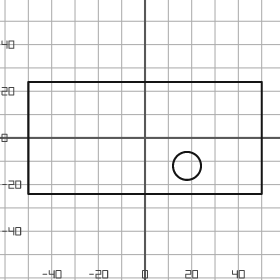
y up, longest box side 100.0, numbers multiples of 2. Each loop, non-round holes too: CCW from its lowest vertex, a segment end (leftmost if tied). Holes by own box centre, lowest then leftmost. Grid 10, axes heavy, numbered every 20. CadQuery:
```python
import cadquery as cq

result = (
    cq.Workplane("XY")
    .moveTo(-50.0, -24.0)
    .lineTo(50.0, -24.0)
    .lineTo(50.0, 24.0)
    .lineTo(-50.0, 24.0)
    .close()
    .moveTo(18.0, -12.0)
    .circle(6.0)
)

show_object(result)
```